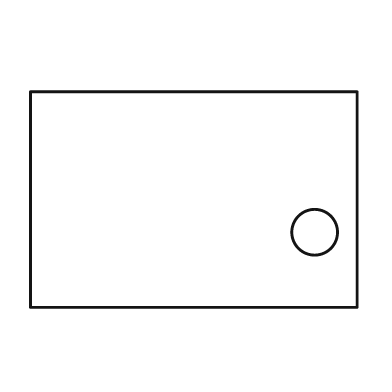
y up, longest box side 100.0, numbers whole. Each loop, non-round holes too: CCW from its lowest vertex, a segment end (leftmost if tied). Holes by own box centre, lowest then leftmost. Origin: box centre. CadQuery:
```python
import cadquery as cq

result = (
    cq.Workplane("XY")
    .moveTo(-50.0, -33.0)
    .lineTo(50.0, -33.0)
    .lineTo(50.0, 33.0)
    .lineTo(-50.0, 33.0)
    .close()
    .moveTo(37.0, -10.0)
    .circle(7.0)
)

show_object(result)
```